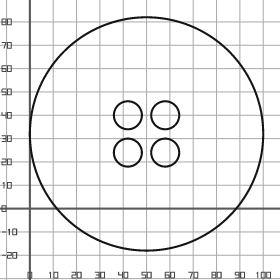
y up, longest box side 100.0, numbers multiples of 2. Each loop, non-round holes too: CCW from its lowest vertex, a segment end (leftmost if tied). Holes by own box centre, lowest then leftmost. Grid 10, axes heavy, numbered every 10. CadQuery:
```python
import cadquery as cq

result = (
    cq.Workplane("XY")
    .moveTo(50.0, 32.0)
    .circle(50.0)
    .moveTo(42.0, 24.0)
    .circle(6.0)
    .moveTo(58.0, 24.0)
    .circle(6.0)
    .moveTo(42.0, 40.0)
    .circle(6.0)
    .moveTo(58.0, 40.0)
    .circle(6.0)
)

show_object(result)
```